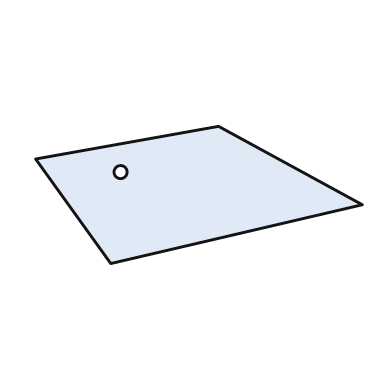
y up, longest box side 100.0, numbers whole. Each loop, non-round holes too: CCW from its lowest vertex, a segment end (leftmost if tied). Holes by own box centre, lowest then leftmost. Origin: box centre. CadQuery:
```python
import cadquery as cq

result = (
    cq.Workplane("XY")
    .moveTo(-27.0, -21.0)
    .lineTo(50.0, -3.0)
    .lineTo(6.0, 21.0)
    .lineTo(-50.0, 11.0)
    .close()
    .moveTo(-24.0, 7.0)
    .circle(2.0)
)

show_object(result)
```